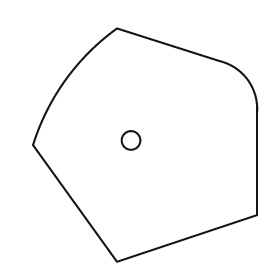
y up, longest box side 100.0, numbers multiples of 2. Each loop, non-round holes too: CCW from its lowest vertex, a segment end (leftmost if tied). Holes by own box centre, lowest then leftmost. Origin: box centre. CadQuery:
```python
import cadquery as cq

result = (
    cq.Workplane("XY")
    .moveTo(-12.0, -50.0)
    .lineTo(48.0, -30.0)
    .lineTo(48.0, 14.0)
    .threePointArc((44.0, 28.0), (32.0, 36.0))
    .lineTo(-12.0, 50.0)
    .threePointArc((-34.0, 28.0), (-48.0, 0.0))
    .close()
    .moveTo(-6.0, 2.0)
    .circle(4.0)
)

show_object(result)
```